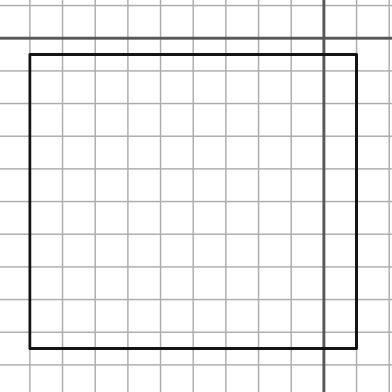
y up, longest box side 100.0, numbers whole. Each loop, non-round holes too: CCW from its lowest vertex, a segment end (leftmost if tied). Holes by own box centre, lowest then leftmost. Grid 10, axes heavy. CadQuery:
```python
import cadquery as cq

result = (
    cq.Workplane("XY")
    .moveTo(-90.0, -95.0)
    .lineTo(10.0, -95.0)
    .lineTo(10.0, -5.0)
    .lineTo(-90.0, -5.0)
    .close()
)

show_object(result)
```